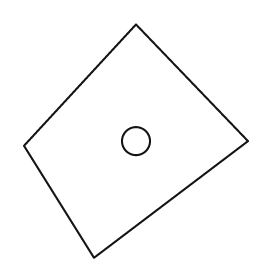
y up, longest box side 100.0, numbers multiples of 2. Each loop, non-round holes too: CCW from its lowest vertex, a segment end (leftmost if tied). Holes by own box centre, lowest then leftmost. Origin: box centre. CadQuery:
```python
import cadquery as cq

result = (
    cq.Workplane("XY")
    .moveTo(-18.0, -50.0)
    .lineTo(48.0, 0.0)
    .lineTo(0.0, 50.0)
    .lineTo(-48.0, -2.0)
    .close()
    .moveTo(0.0, 0.0)
    .circle(6.0)
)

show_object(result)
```